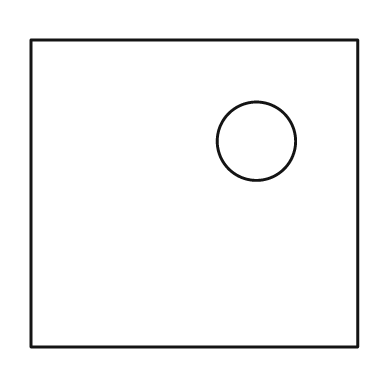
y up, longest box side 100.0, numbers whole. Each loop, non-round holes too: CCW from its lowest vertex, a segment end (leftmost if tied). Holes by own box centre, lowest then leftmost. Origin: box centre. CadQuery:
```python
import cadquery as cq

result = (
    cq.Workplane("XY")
    .moveTo(-50.0, -47.0)
    .lineTo(50.0, -47.0)
    .lineTo(50.0, 47.0)
    .lineTo(-50.0, 47.0)
    .close()
    .moveTo(19.0, 16.0)
    .circle(12.0)
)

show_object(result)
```